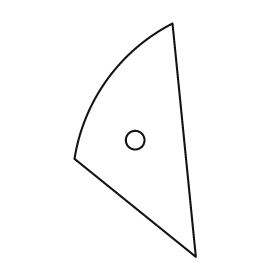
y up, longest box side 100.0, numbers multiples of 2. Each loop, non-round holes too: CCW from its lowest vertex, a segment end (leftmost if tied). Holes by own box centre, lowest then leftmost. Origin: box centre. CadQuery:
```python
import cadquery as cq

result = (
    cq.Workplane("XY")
    .moveTo(26.0, -50.0)
    .lineTo(16.0, 50.0)
    .threePointArc((-12.0, 26.0), (-26.0, -8.0))
    .close()
    .moveTo(0.0, 0.0)
    .circle(4.0)
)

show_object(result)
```